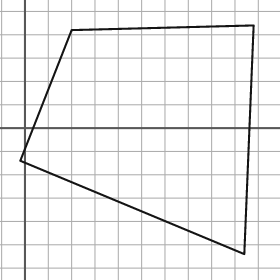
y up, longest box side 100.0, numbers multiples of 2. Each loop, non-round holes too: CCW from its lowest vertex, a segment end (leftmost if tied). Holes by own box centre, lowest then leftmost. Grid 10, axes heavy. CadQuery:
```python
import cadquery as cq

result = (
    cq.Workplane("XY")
    .moveTo(94.0, -54.0)
    .lineTo(98.0, 44.0)
    .lineTo(20.0, 42.0)
    .lineTo(-2.0, -14.0)
    .close()
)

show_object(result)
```